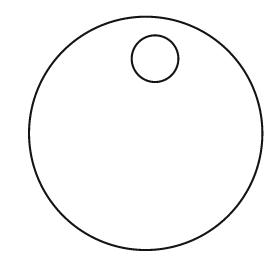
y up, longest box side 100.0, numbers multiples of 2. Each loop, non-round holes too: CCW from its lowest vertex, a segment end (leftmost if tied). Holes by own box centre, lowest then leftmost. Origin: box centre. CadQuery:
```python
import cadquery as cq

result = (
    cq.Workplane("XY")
    .moveTo(0.0, 0.0)
    .circle(50.0)
    .moveTo(4.0, 32.0)
    .circle(10.0)
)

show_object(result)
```